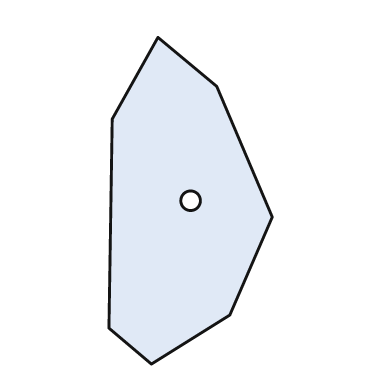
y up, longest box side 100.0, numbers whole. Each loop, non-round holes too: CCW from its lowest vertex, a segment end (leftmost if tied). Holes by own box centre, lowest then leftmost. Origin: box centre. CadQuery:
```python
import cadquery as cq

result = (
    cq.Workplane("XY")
    .moveTo(-12.0, -50.0)
    .lineTo(12.0, -35.0)
    .lineTo(25.0, -5.0)
    .lineTo(8.0, 35.0)
    .lineTo(-10.0, 50.0)
    .lineTo(-24.0, 25.0)
    .lineTo(-25.0, -39.0)
    .close()
    .moveTo(0.0, 0.0)
    .circle(3.0)
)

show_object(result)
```